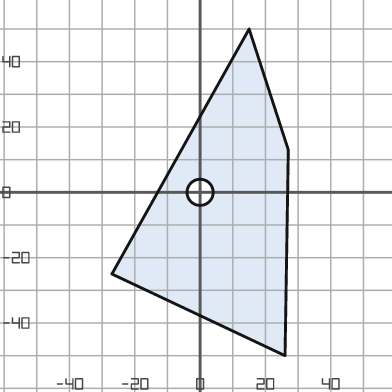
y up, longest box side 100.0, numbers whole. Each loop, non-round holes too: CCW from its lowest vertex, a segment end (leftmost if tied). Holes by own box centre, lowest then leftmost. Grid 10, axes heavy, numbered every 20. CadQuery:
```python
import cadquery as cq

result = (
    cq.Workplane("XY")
    .moveTo(26.0, -50.0)
    .lineTo(27.0, 13.0)
    .lineTo(15.0, 50.0)
    .lineTo(-27.0, -25.0)
    .close()
    .moveTo(0.0, 0.0)
    .circle(4.0)
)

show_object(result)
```